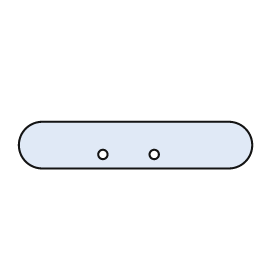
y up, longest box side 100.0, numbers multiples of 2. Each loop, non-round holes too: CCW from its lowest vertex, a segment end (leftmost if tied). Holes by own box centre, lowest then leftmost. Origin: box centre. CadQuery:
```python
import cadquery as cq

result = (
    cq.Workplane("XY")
    .moveTo(-40.0, -10.0)
    .lineTo(40.0, -10.0)
    .threePointArc((50.0, 0.0), (40.0, 10.0))
    .lineTo(-40.0, 10.0)
    .threePointArc((-50.0, 0.0), (-40.0, -10.0))
    .close()
    .moveTo(-14.0, -4.0)
    .circle(2.0)
    .moveTo(8.0, -4.0)
    .circle(2.0)
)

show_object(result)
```